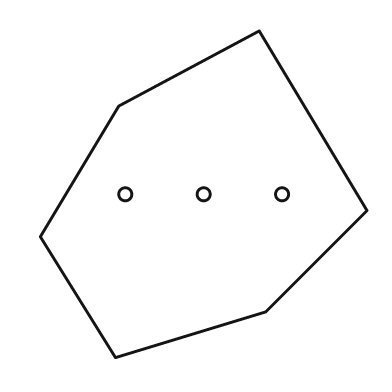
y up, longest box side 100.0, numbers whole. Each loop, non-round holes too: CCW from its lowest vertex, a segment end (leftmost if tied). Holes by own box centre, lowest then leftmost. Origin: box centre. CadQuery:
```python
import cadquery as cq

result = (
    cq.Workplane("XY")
    .moveTo(-27.0, -50.0)
    .lineTo(19.0, -36.0)
    .lineTo(50.0, -5.0)
    .lineTo(17.0, 50.0)
    .lineTo(-26.0, 27.0)
    .lineTo(-50.0, -13.0)
    .close()
    .moveTo(-24.0, 0.0)
    .circle(2.0)
    .moveTo(0.0, 0.0)
    .circle(2.0)
    .moveTo(24.0, 0.0)
    .circle(2.0)
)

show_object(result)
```